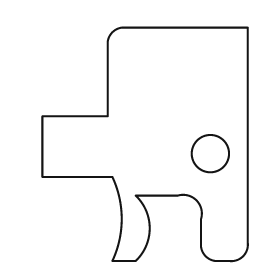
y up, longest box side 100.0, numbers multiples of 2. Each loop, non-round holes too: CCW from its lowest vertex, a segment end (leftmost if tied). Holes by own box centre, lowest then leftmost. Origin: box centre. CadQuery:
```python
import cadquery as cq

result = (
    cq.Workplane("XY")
    .moveTo(-14.0, -50.0)
    .lineTo(-4.0, -50.0)
    .threePointArc((2.0, -36.0), (-4.0, -22.0))
    .lineTo(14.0, -22.0)
    .threePointArc((22.0, -24.0), (24.0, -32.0))
    .lineTo(24.0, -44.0)
    .threePointArc((26.0, -48.0), (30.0, -50.0))
    .lineTo(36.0, -50.0)
    .threePointArc((42.0, -48.0), (44.0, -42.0))
    .lineTo(44.0, 50.0)
    .lineTo(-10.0, 50.0)
    .threePointArc((-14.0, 48.0), (-16.0, 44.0))
    .lineTo(-16.0, 12.0)
    .lineTo(-44.0, 12.0)
    .lineTo(-44.0, -14.0)
    .lineTo(-14.0, -14.0)
    .threePointArc((-10.0, -32.0), (-14.0, -50.0))
    .close()
    .moveTo(28.0, -4.0)
    .circle(8.0)
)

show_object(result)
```